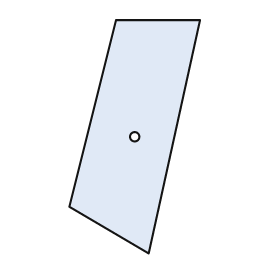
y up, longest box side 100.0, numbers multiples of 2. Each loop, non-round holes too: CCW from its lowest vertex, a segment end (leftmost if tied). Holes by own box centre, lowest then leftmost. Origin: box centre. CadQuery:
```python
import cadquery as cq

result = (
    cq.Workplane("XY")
    .moveTo(6.0, -50.0)
    .lineTo(28.0, 50.0)
    .lineTo(-8.0, 50.0)
    .lineTo(-28.0, -30.0)
    .close()
    .moveTo(0.0, 0.0)
    .circle(2.0)
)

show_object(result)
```